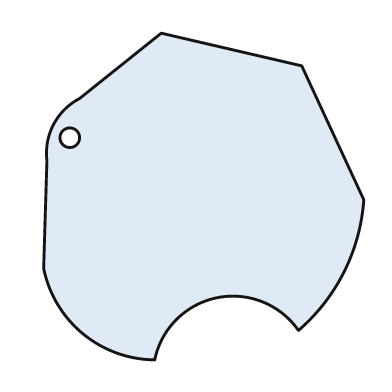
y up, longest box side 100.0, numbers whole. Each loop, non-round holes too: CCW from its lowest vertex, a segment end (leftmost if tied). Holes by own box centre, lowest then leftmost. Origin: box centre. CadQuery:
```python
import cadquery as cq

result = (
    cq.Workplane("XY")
    .moveTo(-15.0, -50.0)
    .threePointArc((4.0, -31.0), (29.0, -41.0))
    .threePointArc((43.0, -23.0), (49.0, -1.0))
    .lineTo(30.0, 40.0)
    .lineTo(-13.0, 50.0)
    .lineTo(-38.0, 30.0)
    .threePointArc((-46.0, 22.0), (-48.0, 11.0))
    .lineTo(-49.0, -22.0)
    .threePointArc((-37.0, -42.0), (-15.0, -50.0))
    .close()
    .moveTo(-41.0, 18.0)
    .circle(3.0)
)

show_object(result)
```